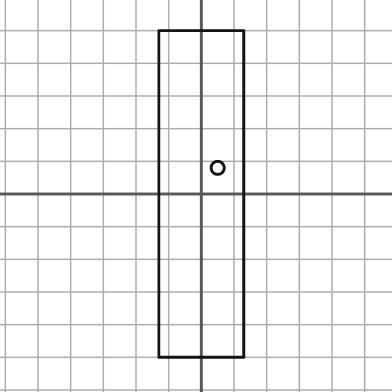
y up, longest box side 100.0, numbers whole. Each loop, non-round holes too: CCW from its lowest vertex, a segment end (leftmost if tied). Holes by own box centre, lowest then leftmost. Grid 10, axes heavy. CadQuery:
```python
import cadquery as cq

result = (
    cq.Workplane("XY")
    .moveTo(-13.0, -50.0)
    .lineTo(13.0, -50.0)
    .lineTo(13.0, 50.0)
    .lineTo(-13.0, 50.0)
    .close()
    .moveTo(5.0, 8.0)
    .circle(2.0)
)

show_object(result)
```